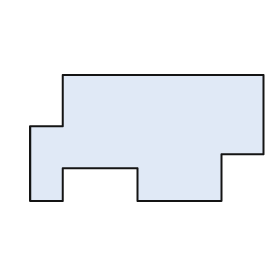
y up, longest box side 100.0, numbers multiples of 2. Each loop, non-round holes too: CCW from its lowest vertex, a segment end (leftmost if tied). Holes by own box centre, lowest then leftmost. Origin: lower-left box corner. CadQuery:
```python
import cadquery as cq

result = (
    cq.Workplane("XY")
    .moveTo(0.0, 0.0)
    .lineTo(14.0, 0.0)
    .lineTo(14.0, 14.0)
    .lineTo(46.0, 14.0)
    .lineTo(46.0, 0.0)
    .lineTo(82.0, 0.0)
    .lineTo(82.0, 20.0)
    .lineTo(100.0, 20.0)
    .lineTo(100.0, 54.0)
    .lineTo(14.0, 54.0)
    .lineTo(14.0, 32.0)
    .lineTo(0.0, 32.0)
    .close()
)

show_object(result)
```